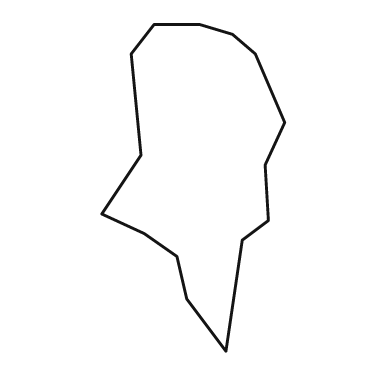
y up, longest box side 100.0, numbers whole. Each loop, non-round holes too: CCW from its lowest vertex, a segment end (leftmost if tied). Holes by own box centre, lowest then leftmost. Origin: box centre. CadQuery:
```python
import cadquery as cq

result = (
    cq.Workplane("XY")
    .moveTo(10.0, -50.0)
    .lineTo(15.0, -16.0)
    .lineTo(23.0, -10.0)
    .lineTo(22.0, 7.0)
    .lineTo(28.0, 20.0)
    .lineTo(19.0, 41.0)
    .lineTo(12.0, 47.0)
    .lineTo(2.0, 50.0)
    .lineTo(-12.0, 50.0)
    .lineTo(-19.0, 41.0)
    .lineTo(-16.0, 10.0)
    .lineTo(-28.0, -8.0)
    .lineTo(-15.0, -14.0)
    .lineTo(-5.0, -21.0)
    .lineTo(-2.0, -34.0)
    .close()
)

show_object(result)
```